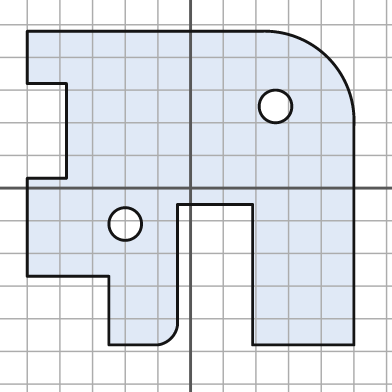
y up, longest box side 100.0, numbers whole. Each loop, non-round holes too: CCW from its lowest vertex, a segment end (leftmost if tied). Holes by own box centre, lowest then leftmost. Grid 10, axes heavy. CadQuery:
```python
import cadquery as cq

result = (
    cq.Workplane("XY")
    .moveTo(-25.0, -48.0)
    .lineTo(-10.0, -48.0)
    .threePointArc((-6.0, -46.0), (-4.0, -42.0))
    .lineTo(-4.0, -5.0)
    .lineTo(19.0, -5.0)
    .lineTo(19.0, -48.0)
    .lineTo(50.0, -48.0)
    .lineTo(50.0, 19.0)
    .threePointArc((42.0, 40.0), (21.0, 48.0))
    .lineTo(-50.0, 48.0)
    .lineTo(-50.0, 32.0)
    .lineTo(-38.0, 32.0)
    .lineTo(-38.0, 3.0)
    .lineTo(-50.0, 3.0)
    .lineTo(-50.0, -27.0)
    .lineTo(-25.0, -27.0)
    .close()
    .moveTo(-20.0, -11.0)
    .circle(5.0)
    .moveTo(26.0, 25.0)
    .circle(5.0)
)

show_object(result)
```